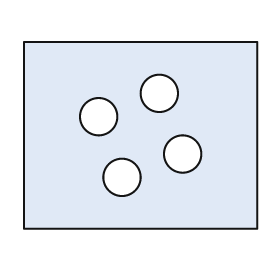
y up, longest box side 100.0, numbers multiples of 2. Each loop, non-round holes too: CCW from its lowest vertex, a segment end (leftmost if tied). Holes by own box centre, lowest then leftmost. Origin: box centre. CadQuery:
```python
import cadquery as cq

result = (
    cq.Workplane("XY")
    .moveTo(-50.0, -40.0)
    .lineTo(50.0, -40.0)
    .lineTo(50.0, 40.0)
    .lineTo(-50.0, 40.0)
    .close()
    .moveTo(-8.0, -18.0)
    .circle(8.0)
    .moveTo(18.0, -8.0)
    .circle(8.0)
    .moveTo(-18.0, 8.0)
    .circle(8.0)
    .moveTo(8.0, 18.0)
    .circle(8.0)
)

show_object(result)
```